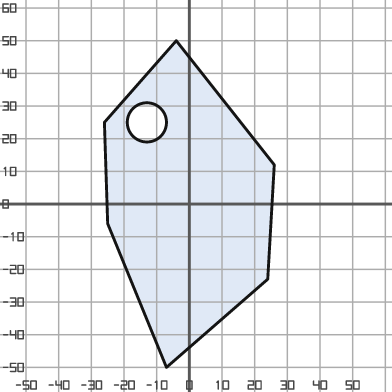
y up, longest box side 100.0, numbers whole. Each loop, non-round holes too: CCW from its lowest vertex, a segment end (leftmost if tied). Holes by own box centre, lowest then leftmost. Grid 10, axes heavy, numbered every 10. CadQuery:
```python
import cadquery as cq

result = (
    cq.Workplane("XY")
    .moveTo(-7.0, -50.0)
    .lineTo(24.0, -23.0)
    .lineTo(26.0, 12.0)
    .lineTo(-4.0, 50.0)
    .lineTo(-26.0, 25.0)
    .lineTo(-25.0, -6.0)
    .close()
    .moveTo(-13.0, 25.0)
    .circle(6.0)
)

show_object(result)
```